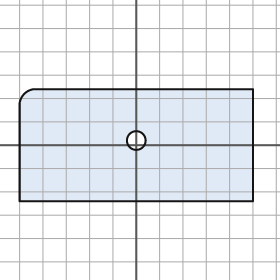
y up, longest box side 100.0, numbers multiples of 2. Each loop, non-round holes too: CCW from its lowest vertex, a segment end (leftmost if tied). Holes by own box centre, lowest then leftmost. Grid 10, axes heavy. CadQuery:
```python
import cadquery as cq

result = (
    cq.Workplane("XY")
    .moveTo(-50.0, -24.0)
    .lineTo(50.0, -24.0)
    .lineTo(50.0, 24.0)
    .lineTo(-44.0, 24.0)
    .threePointArc((-48.0, 22.0), (-50.0, 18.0))
    .close()
    .moveTo(0.0, 2.0)
    .circle(4.0)
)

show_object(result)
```